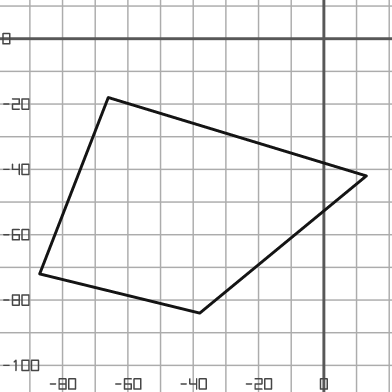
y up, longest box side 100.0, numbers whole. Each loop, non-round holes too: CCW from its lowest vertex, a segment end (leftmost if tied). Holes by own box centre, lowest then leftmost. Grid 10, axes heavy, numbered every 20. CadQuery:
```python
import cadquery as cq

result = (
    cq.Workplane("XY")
    .moveTo(-38.0, -84.0)
    .lineTo(13.0, -42.0)
    .lineTo(-66.0, -18.0)
    .lineTo(-87.0, -72.0)
    .close()
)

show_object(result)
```